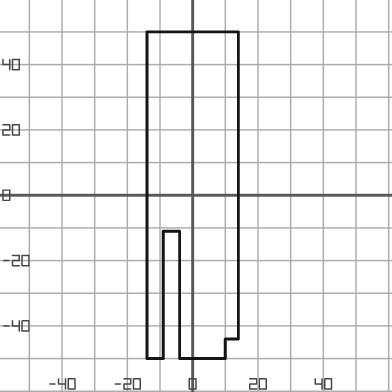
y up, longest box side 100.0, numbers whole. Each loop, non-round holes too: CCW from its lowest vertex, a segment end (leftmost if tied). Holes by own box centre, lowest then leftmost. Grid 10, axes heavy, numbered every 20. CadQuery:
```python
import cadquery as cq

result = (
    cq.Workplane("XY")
    .moveTo(-14.0, -50.0)
    .lineTo(-9.0, -50.0)
    .lineTo(-9.0, -11.0)
    .lineTo(-4.0, -11.0)
    .lineTo(-4.0, -50.0)
    .lineTo(10.0, -50.0)
    .lineTo(10.0, -44.0)
    .lineTo(14.0, -44.0)
    .lineTo(14.0, 50.0)
    .lineTo(-14.0, 50.0)
    .close()
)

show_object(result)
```